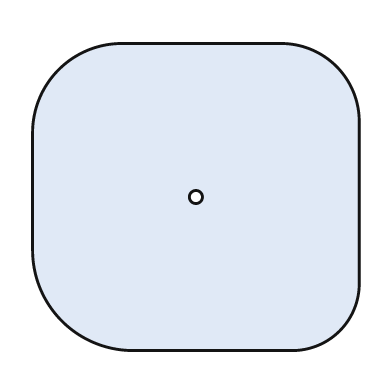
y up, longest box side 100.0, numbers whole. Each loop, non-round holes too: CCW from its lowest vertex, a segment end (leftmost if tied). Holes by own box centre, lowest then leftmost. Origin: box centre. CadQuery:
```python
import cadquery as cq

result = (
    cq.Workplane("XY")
    .moveTo(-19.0, -47.0)
    .lineTo(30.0, -47.0)
    .threePointArc((44.0, -41.0), (50.0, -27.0))
    .lineTo(50.0, 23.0)
    .threePointArc((43.0, 40.0), (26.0, 47.0))
    .lineTo(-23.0, 47.0)
    .threePointArc((-42.0, 39.0), (-50.0, 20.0))
    .lineTo(-50.0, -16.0)
    .threePointArc((-41.0, -38.0), (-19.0, -47.0))
    .close()
    .moveTo(0.0, 0.0)
    .circle(2.0)
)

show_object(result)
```